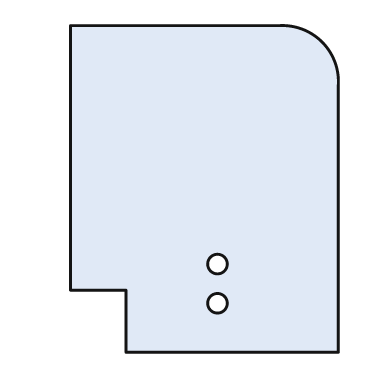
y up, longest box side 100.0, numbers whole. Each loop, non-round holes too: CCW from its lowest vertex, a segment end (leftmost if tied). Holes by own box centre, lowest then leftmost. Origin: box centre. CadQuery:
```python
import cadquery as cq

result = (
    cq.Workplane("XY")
    .moveTo(-24.0, -50.0)
    .lineTo(41.0, -50.0)
    .lineTo(41.0, 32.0)
    .threePointArc((36.0, 45.0), (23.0, 50.0))
    .lineTo(-41.0, 50.0)
    .lineTo(-41.0, -31.0)
    .lineTo(-24.0, -31.0)
    .close()
    .moveTo(4.0, -35.0)
    .circle(3.0)
    .moveTo(4.0, -23.0)
    .circle(3.0)
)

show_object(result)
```